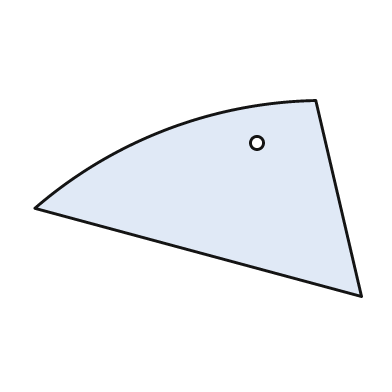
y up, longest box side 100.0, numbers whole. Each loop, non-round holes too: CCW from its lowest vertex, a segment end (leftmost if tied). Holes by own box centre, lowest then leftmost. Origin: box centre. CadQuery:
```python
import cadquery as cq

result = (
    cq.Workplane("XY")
    .moveTo(50.0, -30.0)
    .lineTo(36.0, 30.0)
    .threePointArc((-10.0, 21.0), (-50.0, -3.0))
    .close()
    .moveTo(18.0, 17.0)
    .circle(2.0)
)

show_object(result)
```